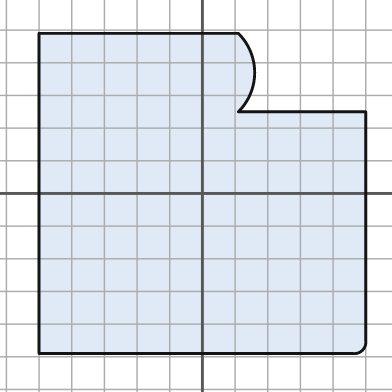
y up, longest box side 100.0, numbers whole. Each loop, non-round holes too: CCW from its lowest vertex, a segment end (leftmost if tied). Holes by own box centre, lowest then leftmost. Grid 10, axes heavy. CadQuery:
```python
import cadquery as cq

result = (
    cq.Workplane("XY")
    .moveTo(-50.0, -49.0)
    .lineTo(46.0, -49.0)
    .threePointArc((49.0, -48.0), (50.0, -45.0))
    .lineTo(50.0, 25.0)
    .lineTo(11.0, 25.0)
    .threePointArc((16.0, 37.0), (11.0, 49.0))
    .lineTo(-50.0, 49.0)
    .close()
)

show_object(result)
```